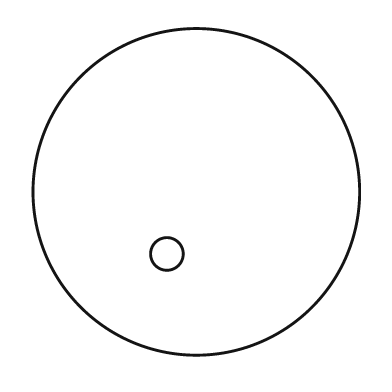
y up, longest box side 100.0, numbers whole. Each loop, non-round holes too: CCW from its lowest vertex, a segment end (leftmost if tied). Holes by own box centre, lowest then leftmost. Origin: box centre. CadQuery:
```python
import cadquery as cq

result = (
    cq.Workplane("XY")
    .moveTo(0.0, 0.0)
    .circle(50.0)
    .moveTo(-9.0, -19.0)
    .circle(5.0)
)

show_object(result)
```